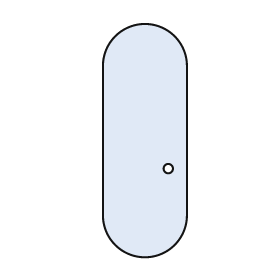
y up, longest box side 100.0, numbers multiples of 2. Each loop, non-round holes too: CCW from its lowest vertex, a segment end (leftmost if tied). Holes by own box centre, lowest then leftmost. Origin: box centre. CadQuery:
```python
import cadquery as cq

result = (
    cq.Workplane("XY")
    .moveTo(-18.0, -32.0)
    .threePointArc((0.0, -50.0), (18.0, -32.0))
    .lineTo(18.0, 32.0)
    .threePointArc((0.0, 50.0), (-18.0, 32.0))
    .close()
    .moveTo(10.0, -12.0)
    .circle(2.0)
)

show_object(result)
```